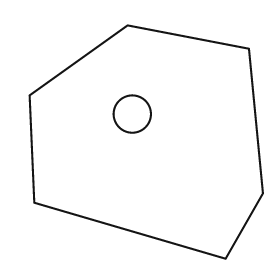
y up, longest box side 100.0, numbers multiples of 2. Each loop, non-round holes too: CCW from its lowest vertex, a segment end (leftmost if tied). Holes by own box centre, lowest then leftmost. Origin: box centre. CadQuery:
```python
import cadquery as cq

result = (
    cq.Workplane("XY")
    .moveTo(34.0, -50.0)
    .lineTo(50.0, -22.0)
    .lineTo(44.0, 40.0)
    .lineTo(-8.0, 50.0)
    .lineTo(-50.0, 20.0)
    .lineTo(-48.0, -26.0)
    .close()
    .moveTo(-6.0, 12.0)
    .circle(8.0)
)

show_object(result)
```